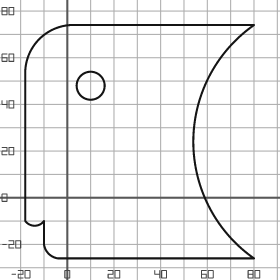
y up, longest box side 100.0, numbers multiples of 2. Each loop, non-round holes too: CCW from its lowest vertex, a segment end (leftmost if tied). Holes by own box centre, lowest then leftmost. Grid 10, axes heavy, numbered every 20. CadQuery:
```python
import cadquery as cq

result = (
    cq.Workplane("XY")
    .moveTo(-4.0, -26.0)
    .lineTo(80.0, -26.0)
    .threePointArc((54.0, 24.0), (80.0, 74.0))
    .lineTo(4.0, 74.0)
    .threePointArc((-12.0, 68.0), (-18.0, 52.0))
    .lineTo(-18.0, -10.0)
    .threePointArc((-14.0, -12.0), (-10.0, -10.0))
    .lineTo(-10.0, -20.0)
    .threePointArc((-8.0, -24.0), (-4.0, -26.0))
    .close()
    .moveTo(10.0, 48.0)
    .circle(6.0)
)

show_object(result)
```